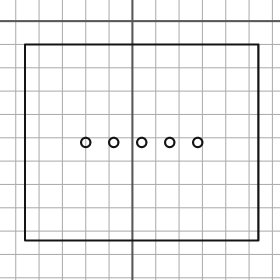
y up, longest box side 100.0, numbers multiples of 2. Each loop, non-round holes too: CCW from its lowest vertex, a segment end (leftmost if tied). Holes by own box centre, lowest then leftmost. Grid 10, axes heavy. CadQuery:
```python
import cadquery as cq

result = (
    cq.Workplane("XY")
    .moveTo(-46.0, -94.0)
    .lineTo(54.0, -94.0)
    .lineTo(54.0, -10.0)
    .lineTo(-46.0, -10.0)
    .close()
    .moveTo(-20.0, -52.0)
    .circle(2.0)
    .moveTo(-8.0, -52.0)
    .circle(2.0)
    .moveTo(4.0, -52.0)
    .circle(2.0)
    .moveTo(16.0, -52.0)
    .circle(2.0)
    .moveTo(28.0, -52.0)
    .circle(2.0)
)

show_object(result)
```